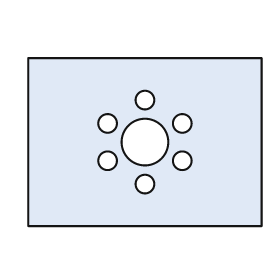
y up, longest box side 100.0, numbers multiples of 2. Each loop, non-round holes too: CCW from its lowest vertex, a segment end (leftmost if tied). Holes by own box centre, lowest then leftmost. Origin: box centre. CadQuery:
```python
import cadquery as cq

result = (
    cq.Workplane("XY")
    .moveTo(-50.0, -36.0)
    .lineTo(50.0, -36.0)
    .lineTo(50.0, 36.0)
    .lineTo(-50.0, 36.0)
    .close()
    .moveTo(0.0, -18.0)
    .circle(4.0)
    .moveTo(-16.0, -8.0)
    .circle(4.0)
    .moveTo(16.0, -8.0)
    .circle(4.0)
    .moveTo(0.0, 0.0)
    .circle(10.0)
    .moveTo(-16.0, 8.0)
    .circle(4.0)
    .moveTo(16.0, 8.0)
    .circle(4.0)
    .moveTo(0.0, 18.0)
    .circle(4.0)
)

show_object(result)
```